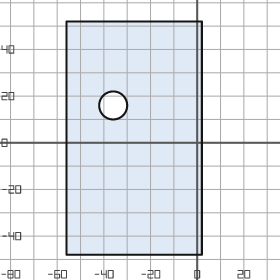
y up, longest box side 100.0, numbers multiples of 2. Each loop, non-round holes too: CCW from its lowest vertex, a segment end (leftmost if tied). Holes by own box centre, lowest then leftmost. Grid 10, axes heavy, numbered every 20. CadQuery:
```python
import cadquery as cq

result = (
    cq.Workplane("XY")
    .moveTo(-56.0, -48.0)
    .lineTo(2.0, -48.0)
    .lineTo(2.0, 52.0)
    .lineTo(-56.0, 52.0)
    .close()
    .moveTo(-36.0, 16.0)
    .circle(6.0)
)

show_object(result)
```